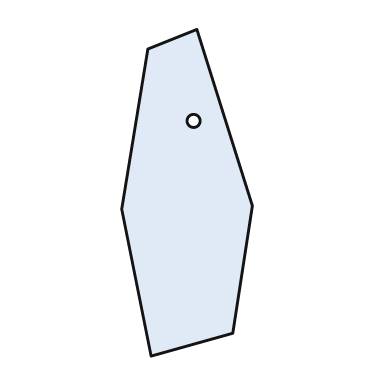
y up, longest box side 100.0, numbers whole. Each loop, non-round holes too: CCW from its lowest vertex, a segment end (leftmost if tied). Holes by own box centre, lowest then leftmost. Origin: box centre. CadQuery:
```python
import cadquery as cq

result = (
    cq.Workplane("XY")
    .moveTo(-11.0, -50.0)
    .lineTo(14.0, -43.0)
    .lineTo(20.0, -4.0)
    .lineTo(3.0, 50.0)
    .lineTo(-12.0, 44.0)
    .lineTo(-20.0, -5.0)
    .close()
    .moveTo(2.0, 22.0)
    .circle(2.0)
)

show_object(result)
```